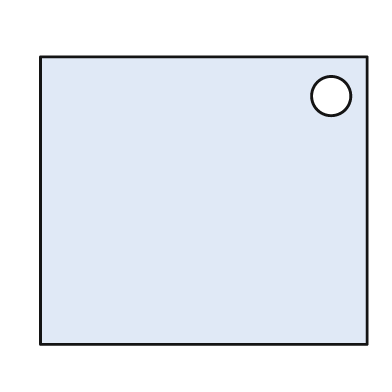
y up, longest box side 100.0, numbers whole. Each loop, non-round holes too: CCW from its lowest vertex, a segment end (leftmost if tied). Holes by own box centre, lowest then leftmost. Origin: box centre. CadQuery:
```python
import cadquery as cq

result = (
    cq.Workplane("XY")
    .moveTo(-50.0, -44.0)
    .lineTo(50.0, -44.0)
    .lineTo(50.0, 44.0)
    .lineTo(-50.0, 44.0)
    .close()
    .moveTo(39.0, 32.0)
    .circle(6.0)
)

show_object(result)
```